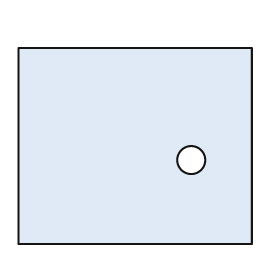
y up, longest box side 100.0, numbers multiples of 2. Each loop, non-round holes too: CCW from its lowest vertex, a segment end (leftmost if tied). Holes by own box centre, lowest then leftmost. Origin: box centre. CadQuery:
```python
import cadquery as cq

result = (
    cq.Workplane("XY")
    .moveTo(-50.0, -42.0)
    .lineTo(50.0, -42.0)
    .lineTo(50.0, 42.0)
    .lineTo(-50.0, 42.0)
    .close()
    .moveTo(24.0, -6.0)
    .circle(6.0)
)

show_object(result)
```